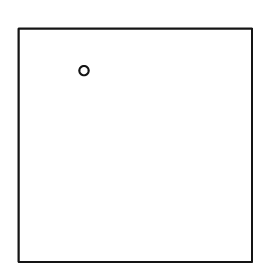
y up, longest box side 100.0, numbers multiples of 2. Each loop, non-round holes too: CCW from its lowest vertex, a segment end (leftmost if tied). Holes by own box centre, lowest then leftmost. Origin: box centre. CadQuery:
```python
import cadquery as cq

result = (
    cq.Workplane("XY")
    .moveTo(-50.0, -50.0)
    .lineTo(50.0, -50.0)
    .lineTo(50.0, 50.0)
    .lineTo(-50.0, 50.0)
    .close()
    .moveTo(-22.0, 32.0)
    .circle(2.0)
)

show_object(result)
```